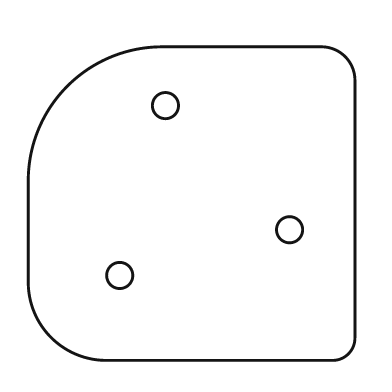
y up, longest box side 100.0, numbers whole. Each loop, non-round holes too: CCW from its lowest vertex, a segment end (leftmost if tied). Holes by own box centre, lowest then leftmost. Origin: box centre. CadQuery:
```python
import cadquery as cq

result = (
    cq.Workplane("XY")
    .moveTo(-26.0, -48.0)
    .lineTo(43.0, -48.0)
    .threePointArc((48.0, -46.0), (50.0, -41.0))
    .lineTo(50.0, 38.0)
    .threePointArc((47.0, 45.0), (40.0, 48.0))
    .lineTo(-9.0, 48.0)
    .threePointArc((-38.0, 36.0), (-50.0, 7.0))
    .lineTo(-50.0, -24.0)
    .threePointArc((-43.0, -41.0), (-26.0, -48.0))
    .close()
    .moveTo(-22.0, -22.0)
    .circle(4.0)
    .moveTo(30.0, -8.0)
    .circle(4.0)
    .moveTo(-8.0, 30.0)
    .circle(4.0)
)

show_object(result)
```